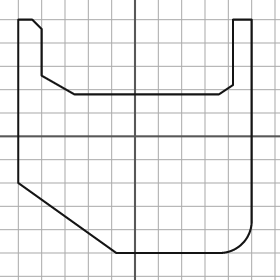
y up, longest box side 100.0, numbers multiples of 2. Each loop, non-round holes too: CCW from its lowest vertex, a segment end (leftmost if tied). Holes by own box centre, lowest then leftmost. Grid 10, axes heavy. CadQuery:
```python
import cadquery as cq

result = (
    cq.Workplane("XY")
    .moveTo(-8.0, -50.0)
    .lineTo(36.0, -50.0)
    .threePointArc((46.0, -46.0), (50.0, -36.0))
    .lineTo(50.0, 50.0)
    .lineTo(42.0, 50.0)
    .lineTo(42.0, 22.0)
    .lineTo(36.0, 18.0)
    .lineTo(-26.0, 18.0)
    .lineTo(-40.0, 26.0)
    .lineTo(-40.0, 46.0)
    .lineTo(-44.0, 50.0)
    .lineTo(-50.0, 50.0)
    .lineTo(-50.0, -20.0)
    .close()
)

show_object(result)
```